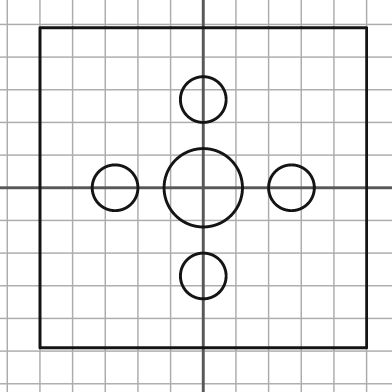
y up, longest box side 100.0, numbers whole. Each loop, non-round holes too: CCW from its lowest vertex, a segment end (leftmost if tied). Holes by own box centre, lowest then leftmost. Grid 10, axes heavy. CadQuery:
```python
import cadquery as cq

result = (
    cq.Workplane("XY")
    .moveTo(-50.0, -49.0)
    .lineTo(50.0, -49.0)
    .lineTo(50.0, 49.0)
    .lineTo(-50.0, 49.0)
    .close()
    .moveTo(0.0, -27.0)
    .circle(7.0)
    .moveTo(-27.0, 0.0)
    .circle(7.0)
    .moveTo(0.0, 0.0)
    .circle(12.0)
    .moveTo(27.0, 0.0)
    .circle(7.0)
    .moveTo(0.0, 27.0)
    .circle(7.0)
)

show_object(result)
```